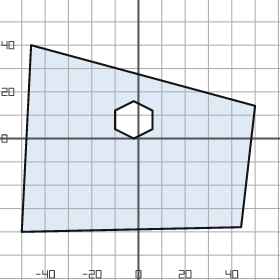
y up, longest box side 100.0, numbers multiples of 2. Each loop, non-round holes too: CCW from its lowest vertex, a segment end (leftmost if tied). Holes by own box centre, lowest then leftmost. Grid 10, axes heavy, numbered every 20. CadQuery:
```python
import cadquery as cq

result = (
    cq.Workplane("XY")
    .moveTo(-50.0, -40.0)
    .lineTo(44.0, -38.0)
    .lineTo(50.0, 14.0)
    .lineTo(-46.0, 40.0)
    .close()
    .moveTo(-2.0, 0.0)
    .lineTo(6.0, 4.0)
    .lineTo(6.0, 12.0)
    .lineTo(-2.0, 16.0)
    .lineTo(-10.0, 12.0)
    .lineTo(-10.0, 4.0)
    .close()
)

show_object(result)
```